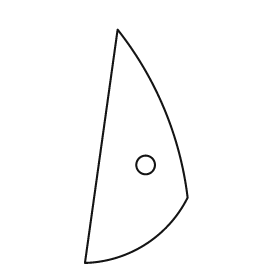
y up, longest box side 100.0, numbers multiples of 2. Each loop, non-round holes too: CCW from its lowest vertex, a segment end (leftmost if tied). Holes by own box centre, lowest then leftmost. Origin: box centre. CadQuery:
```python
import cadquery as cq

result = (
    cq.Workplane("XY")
    .moveTo(-22.0, -50.0)
    .threePointArc((4.0, -42.0), (22.0, -22.0))
    .threePointArc((12.0, 16.0), (-8.0, 50.0))
    .close()
    .moveTo(4.0, -8.0)
    .circle(4.0)
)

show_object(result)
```